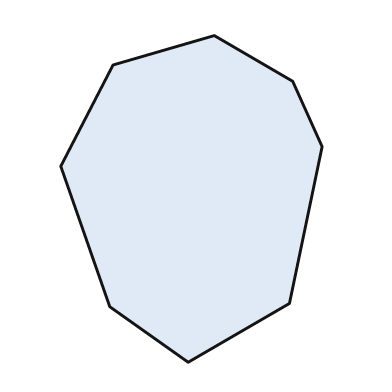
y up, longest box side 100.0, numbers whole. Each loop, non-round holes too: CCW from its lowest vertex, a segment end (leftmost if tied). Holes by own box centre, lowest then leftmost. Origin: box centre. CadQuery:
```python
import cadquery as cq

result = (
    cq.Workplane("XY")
    .moveTo(-1.0, -50.0)
    .lineTo(30.0, -32.0)
    .lineTo(40.0, 16.0)
    .lineTo(31.0, 36.0)
    .lineTo(7.0, 50.0)
    .lineTo(-24.0, 41.0)
    .lineTo(-40.0, 10.0)
    .lineTo(-25.0, -33.0)
    .close()
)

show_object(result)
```